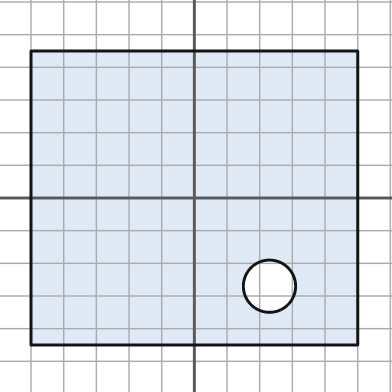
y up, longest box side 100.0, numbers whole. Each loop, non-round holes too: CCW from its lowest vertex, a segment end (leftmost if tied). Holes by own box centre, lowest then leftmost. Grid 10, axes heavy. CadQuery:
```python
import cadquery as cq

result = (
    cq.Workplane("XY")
    .moveTo(-50.0, -45.0)
    .lineTo(50.0, -45.0)
    .lineTo(50.0, 45.0)
    .lineTo(-50.0, 45.0)
    .close()
    .moveTo(23.0, -27.0)
    .circle(8.0)
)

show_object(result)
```